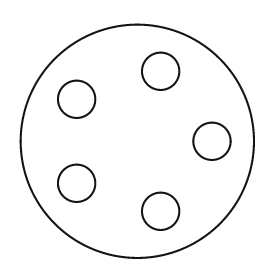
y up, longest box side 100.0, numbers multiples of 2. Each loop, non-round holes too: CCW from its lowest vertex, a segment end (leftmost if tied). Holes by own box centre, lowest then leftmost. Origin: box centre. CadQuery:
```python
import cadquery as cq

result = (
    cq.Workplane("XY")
    .moveTo(0.0, 0.0)
    .circle(50.0)
    .moveTo(10.0, -30.0)
    .circle(8.0)
    .moveTo(-26.0, -18.0)
    .circle(8.0)
    .moveTo(32.0, 0.0)
    .circle(8.0)
    .moveTo(-26.0, 18.0)
    .circle(8.0)
    .moveTo(10.0, 30.0)
    .circle(8.0)
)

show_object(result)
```